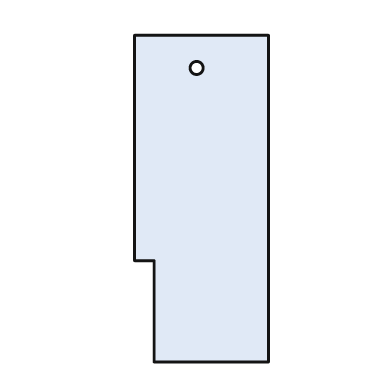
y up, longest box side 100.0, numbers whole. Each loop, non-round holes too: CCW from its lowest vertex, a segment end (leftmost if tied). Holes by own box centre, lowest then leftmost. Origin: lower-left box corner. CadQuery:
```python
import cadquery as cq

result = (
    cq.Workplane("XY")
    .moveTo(6.0, 0.0)
    .lineTo(41.0, 0.0)
    .lineTo(41.0, 100.0)
    .lineTo(0.0, 100.0)
    .lineTo(0.0, 31.0)
    .lineTo(6.0, 31.0)
    .close()
    .moveTo(19.0, 90.0)
    .circle(2.0)
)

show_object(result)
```